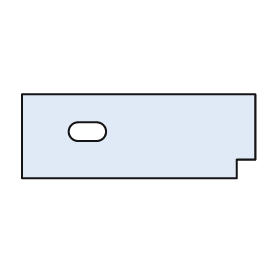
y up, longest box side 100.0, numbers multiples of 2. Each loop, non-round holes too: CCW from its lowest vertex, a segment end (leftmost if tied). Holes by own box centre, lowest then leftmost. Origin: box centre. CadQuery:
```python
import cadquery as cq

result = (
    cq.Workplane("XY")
    .moveTo(-50.0, -18.0)
    .lineTo(42.0, -18.0)
    .lineTo(42.0, -10.0)
    .lineTo(50.0, -10.0)
    .lineTo(50.0, 18.0)
    .lineTo(-50.0, 18.0)
    .close()
    .moveTo(-26.0, -2.0)
    .lineTo(-18.0, -2.0)
    .threePointArc((-14.0, 2.0), (-18.0, 6.0))
    .lineTo(-26.0, 6.0)
    .threePointArc((-30.0, 2.0), (-26.0, -2.0))
    .close()
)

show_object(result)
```